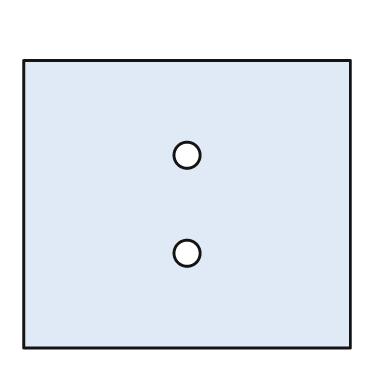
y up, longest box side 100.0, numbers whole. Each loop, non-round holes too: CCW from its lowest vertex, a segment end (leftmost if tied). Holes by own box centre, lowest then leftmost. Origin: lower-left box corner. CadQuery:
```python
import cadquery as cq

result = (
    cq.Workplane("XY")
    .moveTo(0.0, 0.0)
    .lineTo(100.0, 0.0)
    .lineTo(100.0, 88.0)
    .lineTo(0.0, 88.0)
    .close()
    .moveTo(50.0, 29.0)
    .circle(4.0)
    .moveTo(50.0, 59.0)
    .circle(4.0)
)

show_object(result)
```